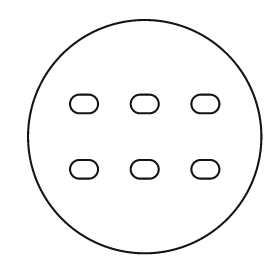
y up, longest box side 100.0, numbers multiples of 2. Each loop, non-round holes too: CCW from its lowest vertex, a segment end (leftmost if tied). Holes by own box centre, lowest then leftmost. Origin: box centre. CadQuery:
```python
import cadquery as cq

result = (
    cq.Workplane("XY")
    .moveTo(0.0, 0.0)
    .circle(50.0)
    .moveTo(-28.0, -18.0)
    .lineTo(-24.0, -18.0)
    .threePointArc((-20.0, -14.0), (-24.0, -10.0))
    .lineTo(-28.0, -10.0)
    .threePointArc((-32.0, -14.0), (-28.0, -18.0))
    .close()
    .moveTo(-2.0, -18.0)
    .lineTo(2.0, -18.0)
    .threePointArc((6.0, -14.0), (2.0, -10.0))
    .lineTo(-2.0, -10.0)
    .threePointArc((-6.0, -14.0), (-2.0, -18.0))
    .close()
    .moveTo(24.0, -18.0)
    .lineTo(28.0, -18.0)
    .threePointArc((32.0, -14.0), (28.0, -10.0))
    .lineTo(24.0, -10.0)
    .threePointArc((20.0, -14.0), (24.0, -18.0))
    .close()
    .moveTo(-28.0, 10.0)
    .lineTo(-24.0, 10.0)
    .threePointArc((-20.0, 14.0), (-24.0, 18.0))
    .lineTo(-28.0, 18.0)
    .threePointArc((-32.0, 14.0), (-28.0, 10.0))
    .close()
    .moveTo(-2.0, 10.0)
    .lineTo(2.0, 10.0)
    .threePointArc((6.0, 14.0), (2.0, 18.0))
    .lineTo(-2.0, 18.0)
    .threePointArc((-6.0, 14.0), (-2.0, 10.0))
    .close()
    .moveTo(24.0, 10.0)
    .lineTo(28.0, 10.0)
    .threePointArc((32.0, 14.0), (28.0, 18.0))
    .lineTo(24.0, 18.0)
    .threePointArc((20.0, 14.0), (24.0, 10.0))
    .close()
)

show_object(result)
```